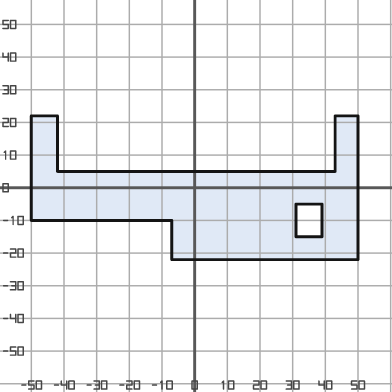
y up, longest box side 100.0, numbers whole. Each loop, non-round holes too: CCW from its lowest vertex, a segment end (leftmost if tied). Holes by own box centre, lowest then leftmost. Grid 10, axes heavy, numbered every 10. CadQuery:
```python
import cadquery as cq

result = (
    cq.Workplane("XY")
    .moveTo(-7.0, -22.0)
    .lineTo(50.0, -22.0)
    .lineTo(50.0, 22.0)
    .lineTo(43.0, 22.0)
    .lineTo(43.0, 5.0)
    .lineTo(-42.0, 5.0)
    .lineTo(-42.0, 22.0)
    .lineTo(-50.0, 22.0)
    .lineTo(-50.0, -10.0)
    .lineTo(-7.0, -10.0)
    .close()
    .moveTo(31.0, -15.0)
    .lineTo(39.0, -15.0)
    .lineTo(39.0, -5.0)
    .lineTo(31.0, -5.0)
    .close()
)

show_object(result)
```